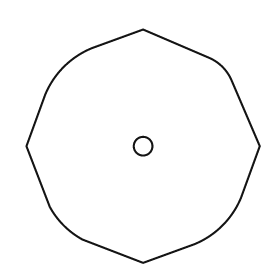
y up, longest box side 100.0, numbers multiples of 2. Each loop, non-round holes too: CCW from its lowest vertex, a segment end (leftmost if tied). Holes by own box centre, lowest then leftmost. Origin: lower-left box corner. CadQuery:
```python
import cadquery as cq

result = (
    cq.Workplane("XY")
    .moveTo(50.0, 0.0)
    .lineTo(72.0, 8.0)
    .threePointArc((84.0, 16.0), (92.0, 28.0))
    .lineTo(100.0, 50.0)
    .lineTo(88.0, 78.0)
    .threePointArc((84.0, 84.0), (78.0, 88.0))
    .lineTo(50.0, 100.0)
    .lineTo(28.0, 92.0)
    .threePointArc((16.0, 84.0), (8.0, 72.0))
    .lineTo(0.0, 50.0)
    .lineTo(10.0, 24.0)
    .threePointArc((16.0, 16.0), (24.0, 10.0))
    .close()
    .moveTo(50.0, 50.0)
    .circle(4.0)
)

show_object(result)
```